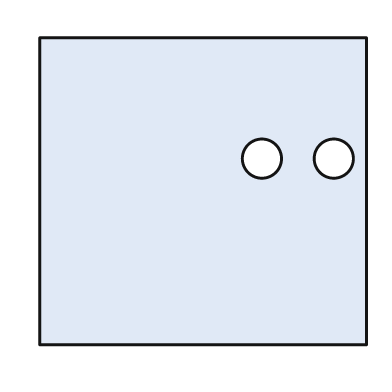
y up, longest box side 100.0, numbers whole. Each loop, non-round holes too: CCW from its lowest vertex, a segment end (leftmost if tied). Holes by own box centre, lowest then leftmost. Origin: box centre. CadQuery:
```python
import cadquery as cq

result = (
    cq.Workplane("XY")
    .moveTo(-50.0, -47.0)
    .lineTo(50.0, -47.0)
    .lineTo(50.0, 47.0)
    .lineTo(-50.0, 47.0)
    .close()
    .moveTo(18.0, 10.0)
    .circle(6.0)
    .moveTo(40.0, 10.0)
    .circle(6.0)
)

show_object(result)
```